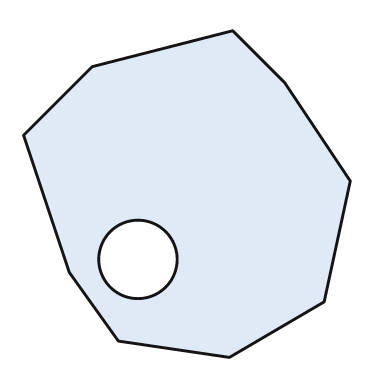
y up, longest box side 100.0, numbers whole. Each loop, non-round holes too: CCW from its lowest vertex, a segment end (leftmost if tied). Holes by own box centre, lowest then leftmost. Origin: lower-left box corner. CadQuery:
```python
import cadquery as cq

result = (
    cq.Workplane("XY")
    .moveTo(63.0, 0.0)
    .lineTo(92.0, 17.0)
    .lineTo(100.0, 54.0)
    .lineTo(80.0, 84.0)
    .lineTo(64.0, 100.0)
    .lineTo(21.0, 89.0)
    .lineTo(0.0, 68.0)
    .lineTo(14.0, 26.0)
    .lineTo(29.0, 5.0)
    .close()
    .moveTo(35.0, 30.0)
    .circle(12.0)
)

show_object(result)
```